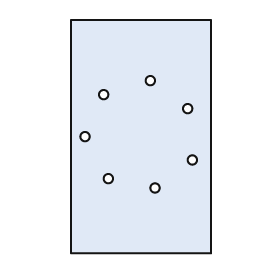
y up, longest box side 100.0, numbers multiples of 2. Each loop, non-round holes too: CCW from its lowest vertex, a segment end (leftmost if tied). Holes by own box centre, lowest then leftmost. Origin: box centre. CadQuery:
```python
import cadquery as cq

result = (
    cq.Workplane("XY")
    .moveTo(-30.0, -50.0)
    .lineTo(30.0, -50.0)
    .lineTo(30.0, 50.0)
    .lineTo(-30.0, 50.0)
    .close()
    .moveTo(6.0, -22.0)
    .circle(2.0)
    .moveTo(-14.0, -18.0)
    .circle(2.0)
    .moveTo(22.0, -10.0)
    .circle(2.0)
    .moveTo(-24.0, 0.0)
    .circle(2.0)
    .moveTo(20.0, 12.0)
    .circle(2.0)
    .moveTo(-16.0, 18.0)
    .circle(2.0)
    .moveTo(4.0, 24.0)
    .circle(2.0)
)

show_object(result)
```